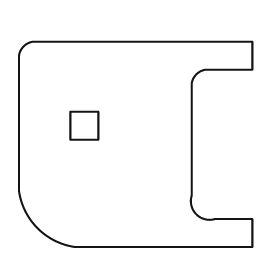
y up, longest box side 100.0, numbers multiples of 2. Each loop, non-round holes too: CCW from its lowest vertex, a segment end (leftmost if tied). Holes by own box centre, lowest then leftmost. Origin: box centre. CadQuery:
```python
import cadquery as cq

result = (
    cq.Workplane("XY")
    .moveTo(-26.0, -44.0)
    .lineTo(50.0, -44.0)
    .lineTo(50.0, -32.0)
    .lineTo(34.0, -32.0)
    .threePointArc((26.0, -30.0), (24.0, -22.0))
    .lineTo(24.0, 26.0)
    .threePointArc((26.0, 30.0), (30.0, 32.0))
    .lineTo(50.0, 32.0)
    .lineTo(50.0, 44.0)
    .lineTo(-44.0, 44.0)
    .threePointArc((-48.0, 42.0), (-50.0, 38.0))
    .lineTo(-50.0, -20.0)
    .threePointArc((-42.0, -36.0), (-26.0, -44.0))
    .close()
    .moveTo(-28.0, 2.0)
    .lineTo(-16.0, 2.0)
    .lineTo(-16.0, 14.0)
    .lineTo(-28.0, 14.0)
    .close()
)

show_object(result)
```